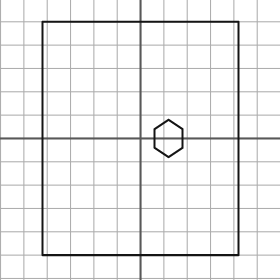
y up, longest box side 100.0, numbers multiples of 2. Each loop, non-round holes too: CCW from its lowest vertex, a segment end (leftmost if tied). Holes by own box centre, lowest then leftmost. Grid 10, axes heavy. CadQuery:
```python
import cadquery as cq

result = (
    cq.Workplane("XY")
    .moveTo(-42.0, -50.0)
    .lineTo(42.0, -50.0)
    .lineTo(42.0, 50.0)
    .lineTo(-42.0, 50.0)
    .close()
    .moveTo(12.0, -8.0)
    .lineTo(18.0, -4.0)
    .lineTo(18.0, 4.0)
    .lineTo(12.0, 8.0)
    .lineTo(6.0, 4.0)
    .lineTo(6.0, -4.0)
    .close()
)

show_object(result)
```